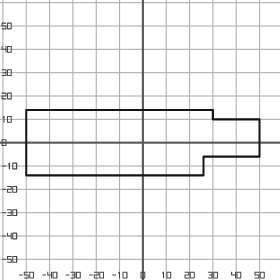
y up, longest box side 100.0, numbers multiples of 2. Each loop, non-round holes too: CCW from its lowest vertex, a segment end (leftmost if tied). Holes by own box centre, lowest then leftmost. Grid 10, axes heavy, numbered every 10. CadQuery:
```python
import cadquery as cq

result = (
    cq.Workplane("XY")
    .moveTo(-50.0, -14.0)
    .lineTo(26.0, -14.0)
    .lineTo(26.0, -6.0)
    .lineTo(50.0, -6.0)
    .lineTo(50.0, 10.0)
    .lineTo(30.0, 10.0)
    .lineTo(30.0, 14.0)
    .lineTo(-50.0, 14.0)
    .close()
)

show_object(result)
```